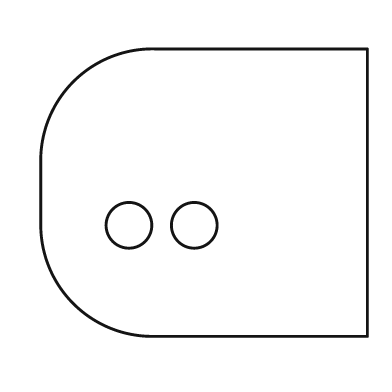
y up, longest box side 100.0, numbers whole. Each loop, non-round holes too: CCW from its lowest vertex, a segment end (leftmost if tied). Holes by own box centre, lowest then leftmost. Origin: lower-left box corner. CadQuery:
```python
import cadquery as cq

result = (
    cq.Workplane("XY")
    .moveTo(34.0, 0.0)
    .lineTo(100.0, 0.0)
    .lineTo(100.0, 88.0)
    .lineTo(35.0, 88.0)
    .threePointArc((10.0, 78.0), (0.0, 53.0))
    .lineTo(0.0, 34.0)
    .threePointArc((10.0, 10.0), (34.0, 0.0))
    .close()
    .moveTo(27.0, 34.0)
    .circle(7.0)
    .moveTo(47.0, 34.0)
    .circle(7.0)
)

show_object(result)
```